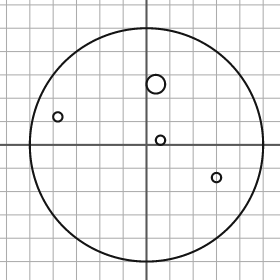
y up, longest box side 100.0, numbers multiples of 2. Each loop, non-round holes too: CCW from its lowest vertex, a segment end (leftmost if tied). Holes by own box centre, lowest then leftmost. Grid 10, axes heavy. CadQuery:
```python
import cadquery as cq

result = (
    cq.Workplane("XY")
    .moveTo(0.0, 0.0)
    .circle(50.0)
    .moveTo(30.0, -14.0)
    .circle(2.0)
    .moveTo(6.0, 2.0)
    .circle(2.0)
    .moveTo(-38.0, 12.0)
    .circle(2.0)
    .moveTo(4.0, 26.0)
    .circle(4.0)
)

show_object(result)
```